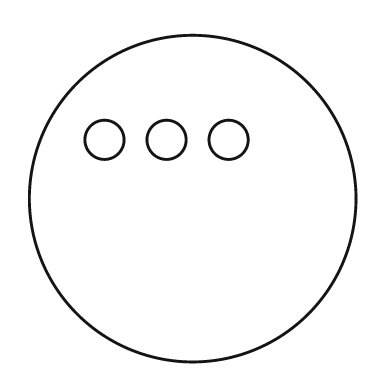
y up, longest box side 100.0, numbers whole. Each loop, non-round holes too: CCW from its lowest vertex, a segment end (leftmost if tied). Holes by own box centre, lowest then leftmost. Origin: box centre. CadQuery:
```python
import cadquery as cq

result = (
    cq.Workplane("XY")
    .moveTo(0.0, 0.0)
    .circle(50.0)
    .moveTo(-27.0, 18.0)
    .circle(6.0)
    .moveTo(-8.0, 18.0)
    .circle(6.0)
    .moveTo(11.0, 18.0)
    .circle(6.0)
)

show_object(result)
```